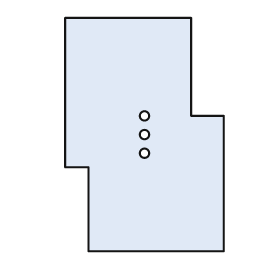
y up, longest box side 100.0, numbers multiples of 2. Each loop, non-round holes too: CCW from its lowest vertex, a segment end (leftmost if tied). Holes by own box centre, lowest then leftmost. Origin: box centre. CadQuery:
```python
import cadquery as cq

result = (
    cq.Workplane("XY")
    .moveTo(-24.0, -50.0)
    .lineTo(34.0, -50.0)
    .lineTo(34.0, 8.0)
    .lineTo(20.0, 8.0)
    .lineTo(20.0, 50.0)
    .lineTo(-34.0, 50.0)
    .lineTo(-34.0, -14.0)
    .lineTo(-24.0, -14.0)
    .close()
    .moveTo(0.0, -8.0)
    .circle(2.0)
    .moveTo(0.0, 0.0)
    .circle(2.0)
    .moveTo(0.0, 8.0)
    .circle(2.0)
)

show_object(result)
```